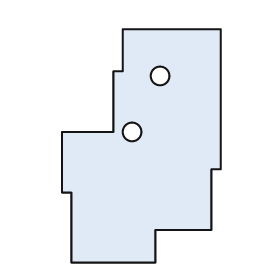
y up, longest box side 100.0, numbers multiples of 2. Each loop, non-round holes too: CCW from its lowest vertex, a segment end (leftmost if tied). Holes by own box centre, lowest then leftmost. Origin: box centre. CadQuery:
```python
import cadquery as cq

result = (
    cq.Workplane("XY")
    .moveTo(-30.0, -50.0)
    .lineTo(6.0, -50.0)
    .lineTo(6.0, -36.0)
    .lineTo(30.0, -36.0)
    .lineTo(30.0, -10.0)
    .lineTo(34.0, -10.0)
    .lineTo(34.0, 50.0)
    .lineTo(-8.0, 50.0)
    .lineTo(-8.0, 32.0)
    .lineTo(-12.0, 32.0)
    .lineTo(-12.0, 6.0)
    .lineTo(-34.0, 6.0)
    .lineTo(-34.0, -20.0)
    .lineTo(-30.0, -20.0)
    .close()
    .moveTo(-4.0, 6.0)
    .circle(4.0)
    .moveTo(8.0, 30.0)
    .circle(4.0)
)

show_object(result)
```